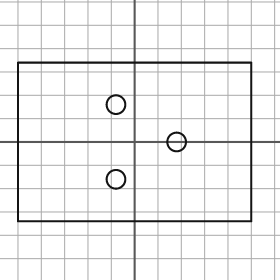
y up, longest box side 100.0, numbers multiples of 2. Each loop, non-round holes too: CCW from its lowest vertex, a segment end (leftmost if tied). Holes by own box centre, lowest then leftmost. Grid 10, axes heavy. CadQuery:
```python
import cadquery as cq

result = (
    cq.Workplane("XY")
    .moveTo(-50.0, -34.0)
    .lineTo(50.0, -34.0)
    .lineTo(50.0, 34.0)
    .lineTo(-50.0, 34.0)
    .close()
    .moveTo(-8.0, -16.0)
    .circle(4.0)
    .moveTo(18.0, 0.0)
    .circle(4.0)
    .moveTo(-8.0, 16.0)
    .circle(4.0)
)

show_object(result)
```